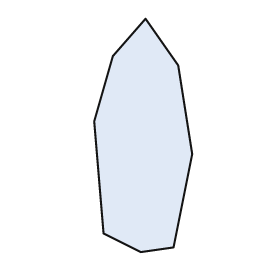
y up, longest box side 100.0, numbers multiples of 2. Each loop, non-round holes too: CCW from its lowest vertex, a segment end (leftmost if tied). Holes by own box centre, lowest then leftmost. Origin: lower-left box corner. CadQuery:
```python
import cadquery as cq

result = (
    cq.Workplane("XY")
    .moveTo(20.0, 0.0)
    .lineTo(34.0, 2.0)
    .lineTo(42.0, 42.0)
    .lineTo(36.0, 80.0)
    .lineTo(22.0, 100.0)
    .lineTo(8.0, 84.0)
    .lineTo(0.0, 56.0)
    .lineTo(4.0, 8.0)
    .close()
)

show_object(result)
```